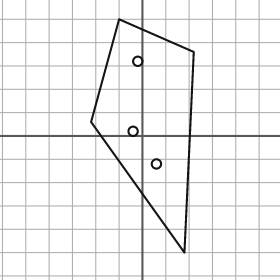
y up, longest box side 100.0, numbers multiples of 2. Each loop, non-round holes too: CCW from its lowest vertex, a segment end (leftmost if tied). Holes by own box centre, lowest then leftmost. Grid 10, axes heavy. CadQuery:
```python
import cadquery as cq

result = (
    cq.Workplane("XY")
    .moveTo(18.0, -50.0)
    .lineTo(22.0, 36.0)
    .lineTo(-10.0, 50.0)
    .lineTo(-22.0, 6.0)
    .close()
    .moveTo(6.0, -12.0)
    .circle(2.0)
    .moveTo(-4.0, 2.0)
    .circle(2.0)
    .moveTo(-2.0, 32.0)
    .circle(2.0)
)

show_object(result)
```